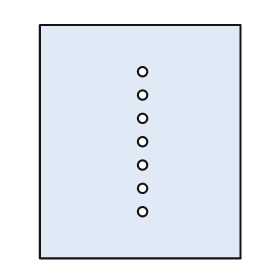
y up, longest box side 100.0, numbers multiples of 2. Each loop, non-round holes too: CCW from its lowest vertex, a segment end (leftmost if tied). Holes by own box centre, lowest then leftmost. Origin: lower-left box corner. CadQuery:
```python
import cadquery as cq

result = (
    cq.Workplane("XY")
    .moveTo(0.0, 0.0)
    .lineTo(86.0, 0.0)
    .lineTo(86.0, 100.0)
    .lineTo(0.0, 100.0)
    .close()
    .moveTo(44.0, 20.0)
    .circle(2.0)
    .moveTo(44.0, 30.0)
    .circle(2.0)
    .moveTo(44.0, 40.0)
    .circle(2.0)
    .moveTo(44.0, 50.0)
    .circle(2.0)
    .moveTo(44.0, 60.0)
    .circle(2.0)
    .moveTo(44.0, 70.0)
    .circle(2.0)
    .moveTo(44.0, 80.0)
    .circle(2.0)
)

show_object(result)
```